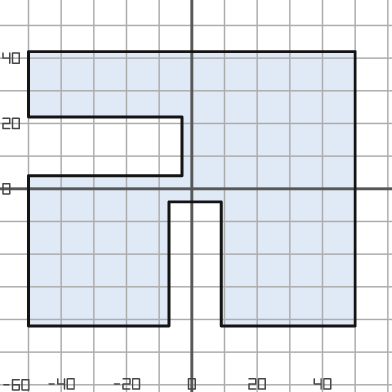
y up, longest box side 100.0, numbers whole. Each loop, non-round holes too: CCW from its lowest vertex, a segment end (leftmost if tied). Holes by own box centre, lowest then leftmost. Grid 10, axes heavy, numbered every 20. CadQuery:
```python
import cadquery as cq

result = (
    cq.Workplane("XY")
    .moveTo(-50.0, -42.0)
    .lineTo(-7.0, -42.0)
    .lineTo(-7.0, -4.0)
    .lineTo(9.0, -4.0)
    .lineTo(9.0, -42.0)
    .lineTo(50.0, -42.0)
    .lineTo(50.0, 42.0)
    .lineTo(-50.0, 42.0)
    .lineTo(-50.0, 22.0)
    .lineTo(-3.0, 22.0)
    .lineTo(-3.0, 4.0)
    .lineTo(-50.0, 4.0)
    .close()
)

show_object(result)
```